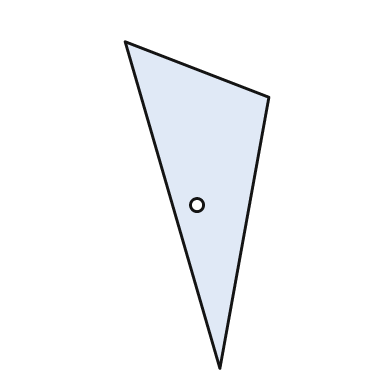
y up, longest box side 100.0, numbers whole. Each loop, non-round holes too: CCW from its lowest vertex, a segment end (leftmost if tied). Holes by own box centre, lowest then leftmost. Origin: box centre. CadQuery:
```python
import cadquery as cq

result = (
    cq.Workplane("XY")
    .moveTo(7.0, -50.0)
    .lineTo(22.0, 33.0)
    .lineTo(-22.0, 50.0)
    .close()
    .moveTo(0.0, 0.0)
    .circle(2.0)
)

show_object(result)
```